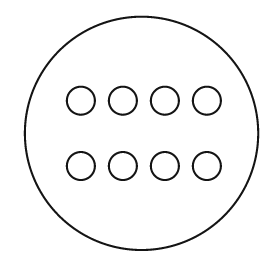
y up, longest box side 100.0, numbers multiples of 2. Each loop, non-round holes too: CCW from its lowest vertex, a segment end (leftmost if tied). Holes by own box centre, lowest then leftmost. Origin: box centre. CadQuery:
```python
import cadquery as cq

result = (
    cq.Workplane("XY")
    .moveTo(0.0, 0.0)
    .circle(50.0)
    .moveTo(-26.0, -14.0)
    .circle(6.0)
    .moveTo(-8.0, -14.0)
    .circle(6.0)
    .moveTo(10.0, -14.0)
    .circle(6.0)
    .moveTo(28.0, -14.0)
    .circle(6.0)
    .moveTo(-26.0, 14.0)
    .circle(6.0)
    .moveTo(-8.0, 14.0)
    .circle(6.0)
    .moveTo(10.0, 14.0)
    .circle(6.0)
    .moveTo(28.0, 14.0)
    .circle(6.0)
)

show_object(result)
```